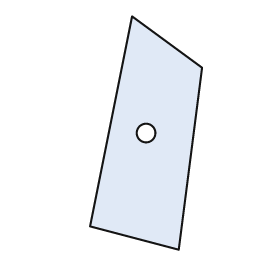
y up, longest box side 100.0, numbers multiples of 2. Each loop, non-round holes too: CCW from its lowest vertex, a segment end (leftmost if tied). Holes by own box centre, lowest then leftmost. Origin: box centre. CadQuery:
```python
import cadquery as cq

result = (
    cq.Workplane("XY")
    .moveTo(14.0, -50.0)
    .lineTo(24.0, 28.0)
    .lineTo(-6.0, 50.0)
    .lineTo(-24.0, -40.0)
    .close()
    .moveTo(0.0, 0.0)
    .circle(4.0)
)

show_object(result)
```